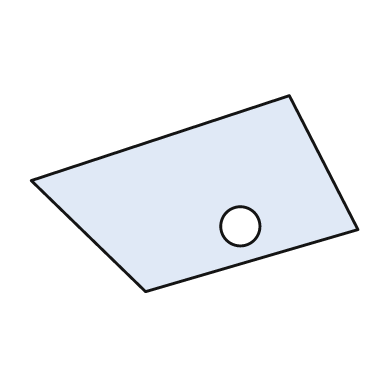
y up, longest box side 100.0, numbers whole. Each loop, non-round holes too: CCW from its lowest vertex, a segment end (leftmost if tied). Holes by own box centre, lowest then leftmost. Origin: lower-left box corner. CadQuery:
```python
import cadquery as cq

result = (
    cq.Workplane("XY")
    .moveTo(35.0, 0.0)
    .lineTo(100.0, 19.0)
    .lineTo(79.0, 60.0)
    .lineTo(0.0, 34.0)
    .close()
    .moveTo(64.0, 20.0)
    .circle(6.0)
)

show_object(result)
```